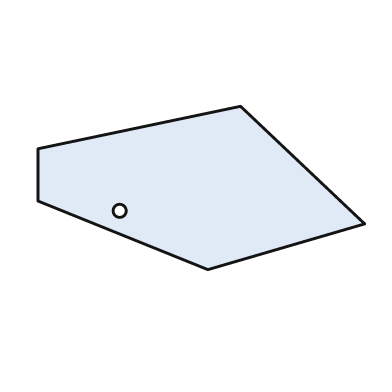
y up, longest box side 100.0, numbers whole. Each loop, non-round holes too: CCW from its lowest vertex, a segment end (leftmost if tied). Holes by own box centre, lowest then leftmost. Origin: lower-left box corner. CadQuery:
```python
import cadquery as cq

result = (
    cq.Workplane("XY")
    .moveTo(52.0, 0.0)
    .lineTo(100.0, 14.0)
    .lineTo(62.0, 50.0)
    .lineTo(0.0, 37.0)
    .lineTo(0.0, 21.0)
    .close()
    .moveTo(25.0, 18.0)
    .circle(2.0)
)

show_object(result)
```